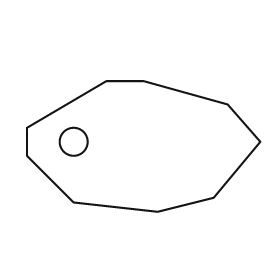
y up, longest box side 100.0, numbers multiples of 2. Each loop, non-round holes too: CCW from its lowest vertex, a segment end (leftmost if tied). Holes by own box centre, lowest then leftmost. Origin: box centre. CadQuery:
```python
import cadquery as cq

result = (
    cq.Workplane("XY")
    .moveTo(6.0, -28.0)
    .lineTo(30.0, -22.0)
    .lineTo(50.0, 2.0)
    .lineTo(36.0, 18.0)
    .lineTo(0.0, 28.0)
    .lineTo(-16.0, 28.0)
    .lineTo(-50.0, 8.0)
    .lineTo(-50.0, -4.0)
    .lineTo(-30.0, -24.0)
    .close()
    .moveTo(-30.0, 2.0)
    .circle(6.0)
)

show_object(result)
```